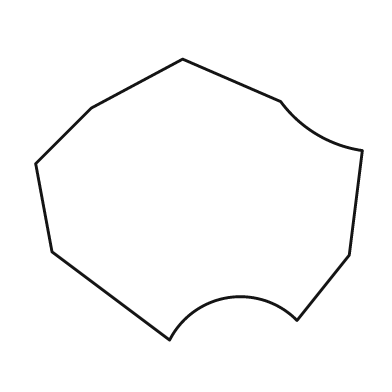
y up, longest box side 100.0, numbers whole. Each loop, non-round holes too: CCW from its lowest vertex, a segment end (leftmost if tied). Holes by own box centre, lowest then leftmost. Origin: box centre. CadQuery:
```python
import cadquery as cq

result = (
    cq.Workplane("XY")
    .moveTo(-9.0, -43.0)
    .threePointArc((9.0, -30.0), (30.0, -37.0))
    .lineTo(46.0, -17.0)
    .lineTo(50.0, 15.0)
    .threePointArc((36.0, 20.0), (25.0, 30.0))
    .lineTo(-5.0, 43.0)
    .lineTo(-33.0, 28.0)
    .lineTo(-50.0, 11.0)
    .lineTo(-45.0, -16.0)
    .close()
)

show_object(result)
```